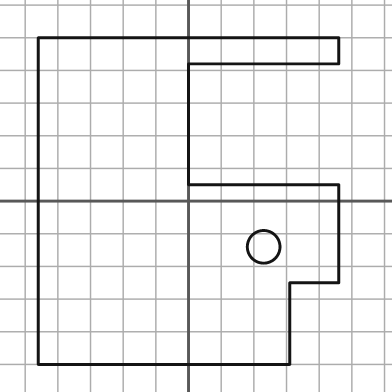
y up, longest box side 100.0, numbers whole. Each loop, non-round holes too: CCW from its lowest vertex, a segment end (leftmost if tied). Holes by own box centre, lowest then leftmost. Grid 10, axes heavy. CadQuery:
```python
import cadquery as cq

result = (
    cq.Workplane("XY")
    .moveTo(-46.0, -50.0)
    .lineTo(31.0, -50.0)
    .lineTo(31.0, -25.0)
    .lineTo(46.0, -25.0)
    .lineTo(46.0, 5.0)
    .lineTo(0.0, 5.0)
    .lineTo(0.0, 42.0)
    .lineTo(46.0, 42.0)
    .lineTo(46.0, 50.0)
    .lineTo(-46.0, 50.0)
    .close()
    .moveTo(23.0, -14.0)
    .circle(5.0)
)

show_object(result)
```